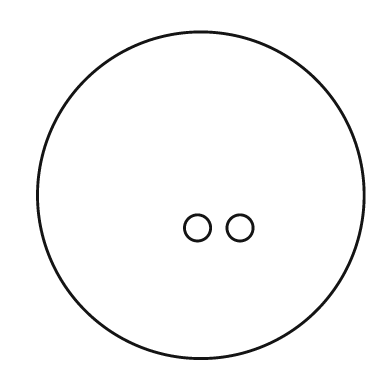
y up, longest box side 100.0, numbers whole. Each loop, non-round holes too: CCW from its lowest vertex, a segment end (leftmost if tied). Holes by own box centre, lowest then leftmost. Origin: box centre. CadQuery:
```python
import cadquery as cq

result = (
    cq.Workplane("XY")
    .moveTo(0.0, 0.0)
    .circle(50.0)
    .moveTo(-1.0, -10.0)
    .circle(4.0)
    .moveTo(12.0, -10.0)
    .circle(4.0)
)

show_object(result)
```